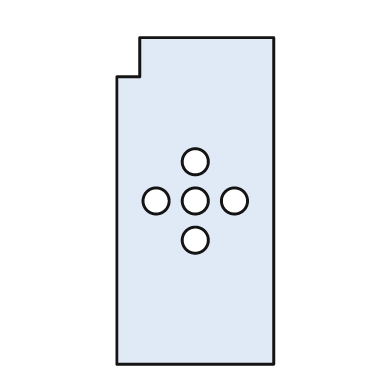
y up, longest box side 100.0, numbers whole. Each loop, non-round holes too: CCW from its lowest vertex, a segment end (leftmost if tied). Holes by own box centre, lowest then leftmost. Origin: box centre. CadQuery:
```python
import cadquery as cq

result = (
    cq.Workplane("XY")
    .moveTo(-24.0, -50.0)
    .lineTo(24.0, -50.0)
    .lineTo(24.0, 50.0)
    .lineTo(-17.0, 50.0)
    .lineTo(-17.0, 38.0)
    .lineTo(-24.0, 38.0)
    .close()
    .moveTo(0.0, -12.0)
    .circle(4.0)
    .moveTo(-12.0, 0.0)
    .circle(4.0)
    .moveTo(0.0, 0.0)
    .circle(4.0)
    .moveTo(12.0, 0.0)
    .circle(4.0)
    .moveTo(0.0, 12.0)
    .circle(4.0)
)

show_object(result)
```